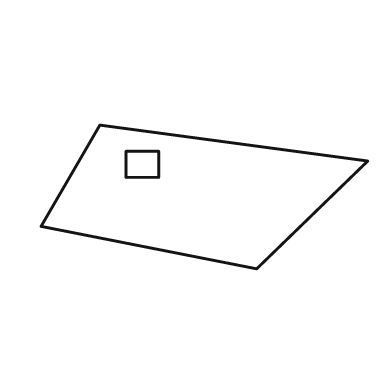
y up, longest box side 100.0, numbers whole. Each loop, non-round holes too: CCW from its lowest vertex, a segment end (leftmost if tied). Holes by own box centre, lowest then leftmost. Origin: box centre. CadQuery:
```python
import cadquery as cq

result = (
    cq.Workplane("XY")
    .moveTo(16.0, -22.0)
    .lineTo(50.0, 11.0)
    .lineTo(-32.0, 22.0)
    .lineTo(-50.0, -9.0)
    .close()
    .moveTo(-24.0, 6.0)
    .lineTo(-14.0, 6.0)
    .lineTo(-14.0, 14.0)
    .lineTo(-24.0, 14.0)
    .close()
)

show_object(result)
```